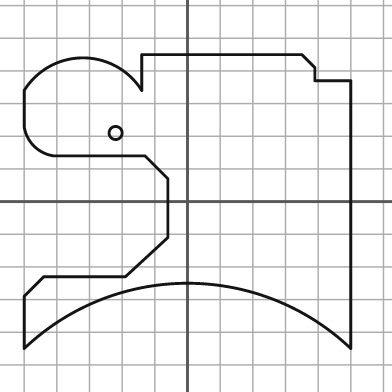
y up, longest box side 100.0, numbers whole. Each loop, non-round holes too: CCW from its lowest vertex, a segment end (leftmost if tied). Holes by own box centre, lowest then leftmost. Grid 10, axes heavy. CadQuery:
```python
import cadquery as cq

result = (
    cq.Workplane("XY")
    .moveTo(-50.0, -45.0)
    .threePointArc((0.0, -25.0), (50.0, -45.0))
    .lineTo(50.0, 37.0)
    .lineTo(39.0, 37.0)
    .lineTo(39.0, 41.0)
    .lineTo(35.0, 45.0)
    .lineTo(-14.0, 45.0)
    .lineTo(-14.0, 34.0)
    .threePointArc((-32.0, 44.0), (-50.0, 34.0))
    .lineTo(-50.0, 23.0)
    .threePointArc((-47.0, 17.0), (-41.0, 14.0))
    .lineTo(-13.0, 14.0)
    .lineTo(-6.0, 7.0)
    .lineTo(-6.0, -11.0)
    .lineTo(-19.0, -23.0)
    .lineTo(-44.0, -23.0)
    .lineTo(-50.0, -29.0)
    .close()
    .moveTo(-22.0, 21.0)
    .circle(2.0)
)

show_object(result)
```